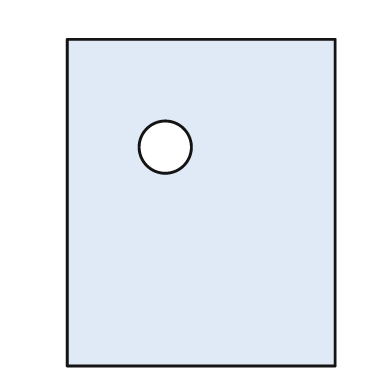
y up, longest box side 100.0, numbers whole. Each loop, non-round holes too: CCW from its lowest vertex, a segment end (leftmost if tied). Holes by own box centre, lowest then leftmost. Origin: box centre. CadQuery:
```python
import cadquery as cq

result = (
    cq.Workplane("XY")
    .moveTo(-41.0, -50.0)
    .lineTo(41.0, -50.0)
    .lineTo(41.0, 50.0)
    .lineTo(-41.0, 50.0)
    .close()
    .moveTo(-11.0, 17.0)
    .circle(8.0)
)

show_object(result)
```